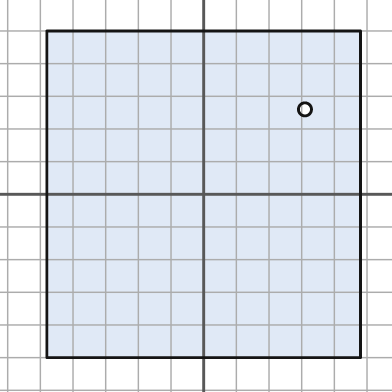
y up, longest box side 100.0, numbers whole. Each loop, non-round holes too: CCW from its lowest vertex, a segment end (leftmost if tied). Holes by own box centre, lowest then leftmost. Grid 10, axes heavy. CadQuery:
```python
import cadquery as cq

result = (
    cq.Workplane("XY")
    .moveTo(-48.0, -50.0)
    .lineTo(48.0, -50.0)
    .lineTo(48.0, 50.0)
    .lineTo(-48.0, 50.0)
    .close()
    .moveTo(31.0, 26.0)
    .circle(2.0)
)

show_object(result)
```